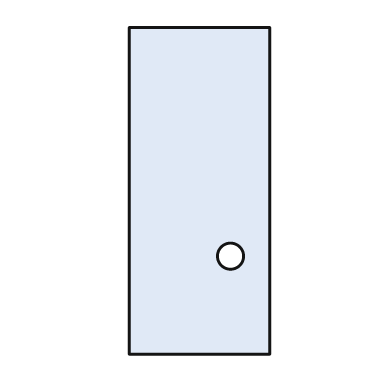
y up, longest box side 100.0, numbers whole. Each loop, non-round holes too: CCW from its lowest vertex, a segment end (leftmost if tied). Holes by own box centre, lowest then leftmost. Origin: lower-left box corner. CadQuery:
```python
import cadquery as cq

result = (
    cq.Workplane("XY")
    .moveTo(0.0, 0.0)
    .lineTo(43.0, 0.0)
    .lineTo(43.0, 100.0)
    .lineTo(0.0, 100.0)
    .close()
    .moveTo(31.0, 30.0)
    .circle(4.0)
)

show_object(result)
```